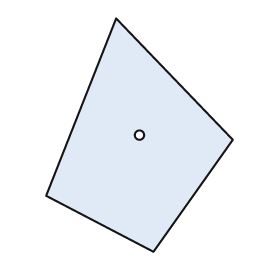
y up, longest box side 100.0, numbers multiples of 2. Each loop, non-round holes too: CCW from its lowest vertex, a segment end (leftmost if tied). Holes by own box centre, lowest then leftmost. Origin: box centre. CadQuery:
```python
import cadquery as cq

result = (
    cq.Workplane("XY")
    .moveTo(6.0, -50.0)
    .lineTo(40.0, -2.0)
    .lineTo(-10.0, 50.0)
    .lineTo(-40.0, -26.0)
    .close()
    .moveTo(0.0, 0.0)
    .circle(2.0)
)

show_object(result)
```